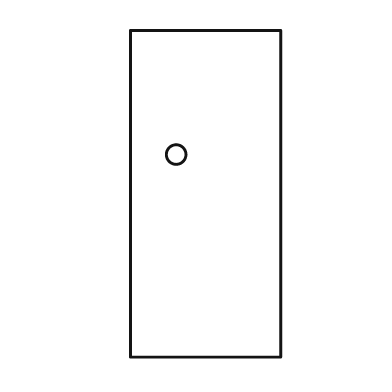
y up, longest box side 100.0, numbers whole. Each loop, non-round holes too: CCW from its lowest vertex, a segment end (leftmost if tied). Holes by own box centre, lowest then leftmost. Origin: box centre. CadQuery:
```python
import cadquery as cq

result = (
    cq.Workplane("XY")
    .moveTo(-23.0, -50.0)
    .lineTo(23.0, -50.0)
    .lineTo(23.0, 50.0)
    .lineTo(-23.0, 50.0)
    .close()
    .moveTo(-9.0, 12.0)
    .circle(3.0)
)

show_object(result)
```